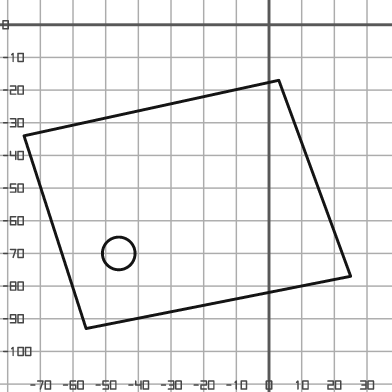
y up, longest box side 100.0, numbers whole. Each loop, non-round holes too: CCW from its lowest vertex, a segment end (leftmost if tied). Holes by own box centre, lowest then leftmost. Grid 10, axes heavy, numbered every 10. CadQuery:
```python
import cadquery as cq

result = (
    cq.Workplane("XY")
    .moveTo(-56.0, -93.0)
    .lineTo(25.0, -77.0)
    .lineTo(3.0, -17.0)
    .lineTo(-75.0, -34.0)
    .close()
    .moveTo(-46.0, -70.0)
    .circle(5.0)
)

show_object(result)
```